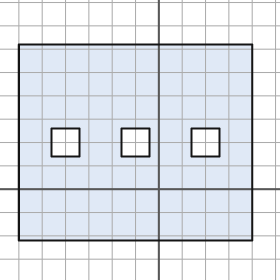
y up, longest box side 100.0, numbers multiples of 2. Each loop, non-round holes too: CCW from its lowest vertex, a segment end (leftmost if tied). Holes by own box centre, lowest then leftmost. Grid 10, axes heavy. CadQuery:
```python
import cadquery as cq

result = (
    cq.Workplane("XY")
    .moveTo(-60.0, -22.0)
    .lineTo(40.0, -22.0)
    .lineTo(40.0, 62.0)
    .lineTo(-60.0, 62.0)
    .close()
    .moveTo(-46.0, 14.0)
    .lineTo(-34.0, 14.0)
    .lineTo(-34.0, 26.0)
    .lineTo(-46.0, 26.0)
    .close()
    .moveTo(-16.0, 14.0)
    .lineTo(-4.0, 14.0)
    .lineTo(-4.0, 26.0)
    .lineTo(-16.0, 26.0)
    .close()
    .moveTo(14.0, 14.0)
    .lineTo(26.0, 14.0)
    .lineTo(26.0, 26.0)
    .lineTo(14.0, 26.0)
    .close()
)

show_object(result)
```